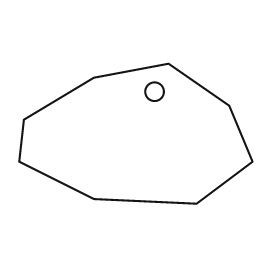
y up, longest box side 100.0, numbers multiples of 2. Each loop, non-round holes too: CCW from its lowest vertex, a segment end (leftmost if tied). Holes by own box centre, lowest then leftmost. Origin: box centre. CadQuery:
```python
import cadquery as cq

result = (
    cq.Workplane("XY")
    .moveTo(26.0, -30.0)
    .lineTo(50.0, -12.0)
    .lineTo(40.0, 12.0)
    .lineTo(14.0, 30.0)
    .lineTo(-18.0, 24.0)
    .lineTo(-48.0, 6.0)
    .lineTo(-50.0, -12.0)
    .lineTo(-18.0, -28.0)
    .close()
    .moveTo(8.0, 18.0)
    .circle(4.0)
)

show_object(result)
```